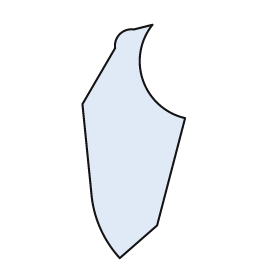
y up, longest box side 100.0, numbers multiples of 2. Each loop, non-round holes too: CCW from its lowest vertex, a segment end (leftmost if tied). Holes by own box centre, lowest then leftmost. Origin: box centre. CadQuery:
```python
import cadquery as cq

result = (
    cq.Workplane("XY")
    .moveTo(-6.0, -50.0)
    .lineTo(10.0, -36.0)
    .lineTo(22.0, 10.0)
    .threePointArc((4.0, 26.0), (8.0, 50.0))
    .lineTo(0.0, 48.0)
    .threePointArc((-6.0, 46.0), (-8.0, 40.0))
    .lineTo(-22.0, 16.0)
    .lineTo(-18.0, -24.0)
    .threePointArc((-14.0, -38.0), (-6.0, -50.0))
    .close()
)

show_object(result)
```